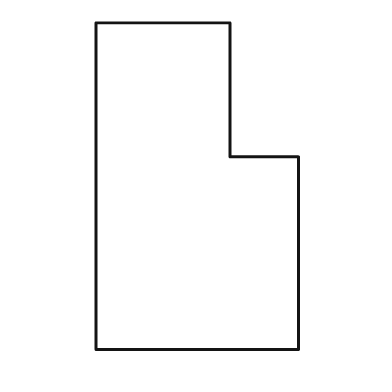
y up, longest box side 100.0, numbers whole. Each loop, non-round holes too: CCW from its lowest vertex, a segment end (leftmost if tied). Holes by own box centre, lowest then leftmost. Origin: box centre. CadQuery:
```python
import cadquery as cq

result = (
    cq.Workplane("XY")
    .moveTo(-31.0, -50.0)
    .lineTo(31.0, -50.0)
    .lineTo(31.0, 9.0)
    .lineTo(10.0, 9.0)
    .lineTo(10.0, 50.0)
    .lineTo(-31.0, 50.0)
    .close()
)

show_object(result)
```